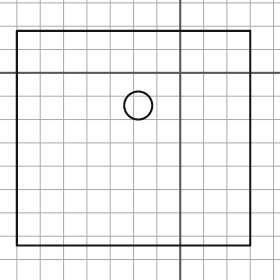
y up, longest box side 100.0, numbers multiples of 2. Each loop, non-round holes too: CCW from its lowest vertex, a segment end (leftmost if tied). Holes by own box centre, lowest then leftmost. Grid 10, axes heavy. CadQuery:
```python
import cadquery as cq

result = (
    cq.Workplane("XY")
    .moveTo(-70.0, -74.0)
    .lineTo(30.0, -74.0)
    .lineTo(30.0, 18.0)
    .lineTo(-70.0, 18.0)
    .close()
    .moveTo(-18.0, -14.0)
    .circle(6.0)
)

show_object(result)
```